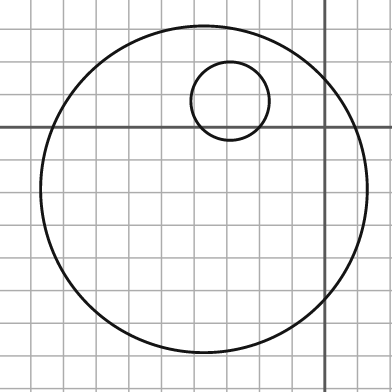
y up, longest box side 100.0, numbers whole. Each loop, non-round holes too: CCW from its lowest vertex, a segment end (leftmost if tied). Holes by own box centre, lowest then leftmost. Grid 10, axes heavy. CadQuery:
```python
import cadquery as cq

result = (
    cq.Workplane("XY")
    .moveTo(-37.0, -19.0)
    .circle(50.0)
    .moveTo(-29.0, 8.0)
    .circle(12.0)
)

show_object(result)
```